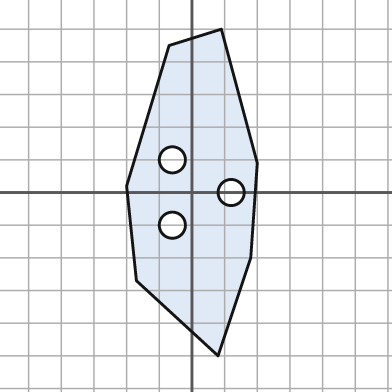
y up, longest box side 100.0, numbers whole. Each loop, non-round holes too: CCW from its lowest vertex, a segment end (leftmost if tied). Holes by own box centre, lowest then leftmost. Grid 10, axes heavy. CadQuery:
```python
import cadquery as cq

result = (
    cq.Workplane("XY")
    .moveTo(8.0, -50.0)
    .lineTo(18.0, -20.0)
    .lineTo(20.0, 9.0)
    .lineTo(9.0, 50.0)
    .lineTo(-7.0, 45.0)
    .lineTo(-20.0, 2.0)
    .lineTo(-17.0, -27.0)
    .close()
    .moveTo(-6.0, -10.0)
    .circle(4.0)
    .moveTo(12.0, 0.0)
    .circle(4.0)
    .moveTo(-6.0, 10.0)
    .circle(4.0)
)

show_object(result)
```